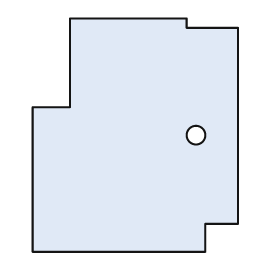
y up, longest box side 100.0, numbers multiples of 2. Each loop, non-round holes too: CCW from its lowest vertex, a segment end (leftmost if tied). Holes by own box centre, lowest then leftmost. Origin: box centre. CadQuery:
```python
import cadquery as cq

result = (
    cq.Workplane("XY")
    .moveTo(-44.0, -50.0)
    .lineTo(30.0, -50.0)
    .lineTo(30.0, -38.0)
    .lineTo(44.0, -38.0)
    .lineTo(44.0, 46.0)
    .lineTo(22.0, 46.0)
    .lineTo(22.0, 50.0)
    .lineTo(-28.0, 50.0)
    .lineTo(-28.0, 12.0)
    .lineTo(-44.0, 12.0)
    .close()
    .moveTo(26.0, 0.0)
    .circle(4.0)
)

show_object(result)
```